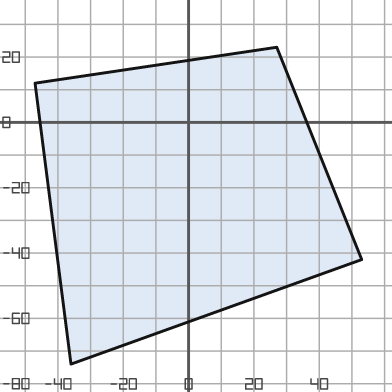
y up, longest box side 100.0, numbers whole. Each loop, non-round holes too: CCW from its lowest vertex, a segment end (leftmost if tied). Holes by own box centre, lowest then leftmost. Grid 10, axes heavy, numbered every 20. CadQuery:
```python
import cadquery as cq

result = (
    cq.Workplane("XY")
    .moveTo(-36.0, -74.0)
    .lineTo(53.0, -42.0)
    .lineTo(27.0, 23.0)
    .lineTo(-47.0, 12.0)
    .close()
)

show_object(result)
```